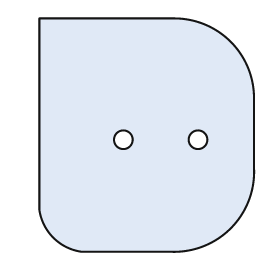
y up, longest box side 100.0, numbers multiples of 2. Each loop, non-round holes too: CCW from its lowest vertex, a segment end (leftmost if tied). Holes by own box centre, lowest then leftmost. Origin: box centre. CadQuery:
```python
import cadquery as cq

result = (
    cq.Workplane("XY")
    .moveTo(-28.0, -50.0)
    .lineTo(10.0, -50.0)
    .threePointArc((36.0, -40.0), (46.0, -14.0))
    .lineTo(46.0, 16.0)
    .threePointArc((36.0, 40.0), (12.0, 50.0))
    .lineTo(-46.0, 50.0)
    .lineTo(-46.0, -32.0)
    .threePointArc((-40.0, -44.0), (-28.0, -50.0))
    .close()
    .moveTo(-10.0, -2.0)
    .circle(4.0)
    .moveTo(22.0, -2.0)
    .circle(4.0)
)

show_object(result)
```